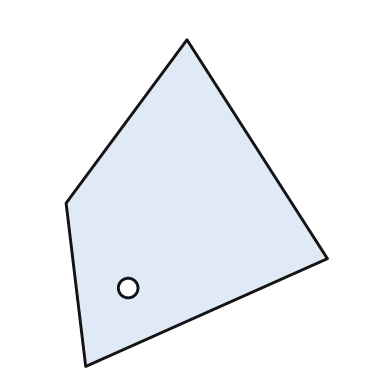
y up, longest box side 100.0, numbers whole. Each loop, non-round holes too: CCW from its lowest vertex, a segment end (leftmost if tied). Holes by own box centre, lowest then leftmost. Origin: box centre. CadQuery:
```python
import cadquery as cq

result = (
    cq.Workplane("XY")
    .moveTo(-34.0, -50.0)
    .lineTo(40.0, -17.0)
    .lineTo(-3.0, 50.0)
    .lineTo(-40.0, 0.0)
    .close()
    .moveTo(-21.0, -26.0)
    .circle(3.0)
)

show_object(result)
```